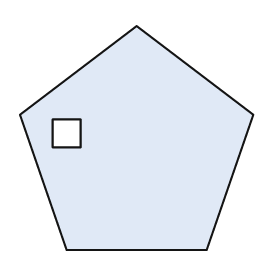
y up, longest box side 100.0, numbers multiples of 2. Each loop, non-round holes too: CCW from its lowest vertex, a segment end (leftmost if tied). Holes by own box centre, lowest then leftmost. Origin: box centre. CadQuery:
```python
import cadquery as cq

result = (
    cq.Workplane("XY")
    .moveTo(-30.0, -48.0)
    .lineTo(30.0, -48.0)
    .lineTo(50.0, 10.0)
    .lineTo(0.0, 48.0)
    .lineTo(-50.0, 10.0)
    .close()
    .moveTo(-36.0, -4.0)
    .lineTo(-24.0, -4.0)
    .lineTo(-24.0, 8.0)
    .lineTo(-36.0, 8.0)
    .close()
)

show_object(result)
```